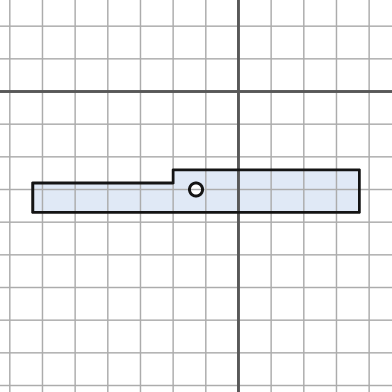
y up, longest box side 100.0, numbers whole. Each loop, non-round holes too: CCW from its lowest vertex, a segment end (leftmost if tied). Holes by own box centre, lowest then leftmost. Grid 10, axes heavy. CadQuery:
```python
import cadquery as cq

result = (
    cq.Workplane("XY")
    .moveTo(-63.0, -37.0)
    .lineTo(37.0, -37.0)
    .lineTo(37.0, -24.0)
    .lineTo(-20.0, -24.0)
    .lineTo(-20.0, -28.0)
    .lineTo(-63.0, -28.0)
    .close()
    .moveTo(-13.0, -30.0)
    .circle(2.0)
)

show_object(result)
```